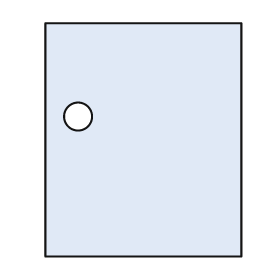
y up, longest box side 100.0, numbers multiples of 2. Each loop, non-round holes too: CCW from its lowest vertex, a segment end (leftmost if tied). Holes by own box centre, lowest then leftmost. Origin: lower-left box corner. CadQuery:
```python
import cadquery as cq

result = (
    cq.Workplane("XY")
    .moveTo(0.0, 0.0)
    .lineTo(84.0, 0.0)
    .lineTo(84.0, 100.0)
    .lineTo(0.0, 100.0)
    .close()
    .moveTo(14.0, 60.0)
    .circle(6.0)
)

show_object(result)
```